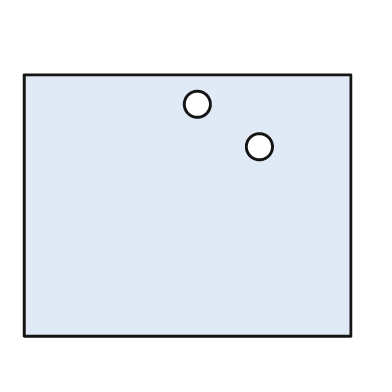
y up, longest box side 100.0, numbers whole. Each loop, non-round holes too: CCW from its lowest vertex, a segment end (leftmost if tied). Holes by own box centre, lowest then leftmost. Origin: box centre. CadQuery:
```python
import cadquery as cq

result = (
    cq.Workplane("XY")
    .moveTo(-50.0, -40.0)
    .lineTo(50.0, -40.0)
    .lineTo(50.0, 40.0)
    .lineTo(-50.0, 40.0)
    .close()
    .moveTo(22.0, 18.0)
    .circle(4.0)
    .moveTo(3.0, 31.0)
    .circle(4.0)
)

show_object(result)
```